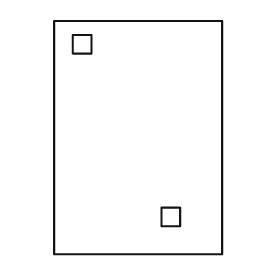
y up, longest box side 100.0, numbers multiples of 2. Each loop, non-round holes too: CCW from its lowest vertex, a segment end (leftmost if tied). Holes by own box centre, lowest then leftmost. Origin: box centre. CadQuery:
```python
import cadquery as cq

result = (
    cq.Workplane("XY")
    .moveTo(-36.0, -50.0)
    .lineTo(36.0, -50.0)
    .lineTo(36.0, 50.0)
    .lineTo(-36.0, 50.0)
    .close()
    .moveTo(10.0, -38.0)
    .lineTo(18.0, -38.0)
    .lineTo(18.0, -30.0)
    .lineTo(10.0, -30.0)
    .close()
    .moveTo(-28.0, 36.0)
    .lineTo(-20.0, 36.0)
    .lineTo(-20.0, 44.0)
    .lineTo(-28.0, 44.0)
    .close()
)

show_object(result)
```